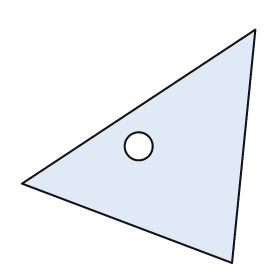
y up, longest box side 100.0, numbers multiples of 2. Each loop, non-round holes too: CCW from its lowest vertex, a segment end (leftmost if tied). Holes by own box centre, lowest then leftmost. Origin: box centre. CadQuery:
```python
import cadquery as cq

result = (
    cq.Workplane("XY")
    .moveTo(40.0, -50.0)
    .lineTo(50.0, 50.0)
    .lineTo(-50.0, -16.0)
    .close()
    .moveTo(0.0, 0.0)
    .circle(6.0)
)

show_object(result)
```